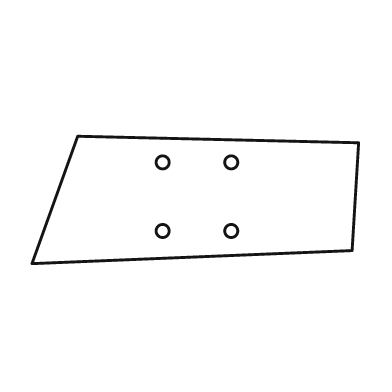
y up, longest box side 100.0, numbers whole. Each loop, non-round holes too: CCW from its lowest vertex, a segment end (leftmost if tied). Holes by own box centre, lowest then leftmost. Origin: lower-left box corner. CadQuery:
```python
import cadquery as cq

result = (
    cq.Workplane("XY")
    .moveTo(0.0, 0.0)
    .lineTo(98.0, 4.0)
    .lineTo(100.0, 37.0)
    .lineTo(14.0, 39.0)
    .close()
    .moveTo(40.0, 10.0)
    .circle(2.0)
    .moveTo(61.0, 10.0)
    .circle(2.0)
    .moveTo(40.0, 31.0)
    .circle(2.0)
    .moveTo(61.0, 31.0)
    .circle(2.0)
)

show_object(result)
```